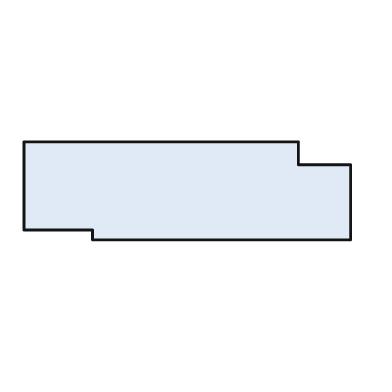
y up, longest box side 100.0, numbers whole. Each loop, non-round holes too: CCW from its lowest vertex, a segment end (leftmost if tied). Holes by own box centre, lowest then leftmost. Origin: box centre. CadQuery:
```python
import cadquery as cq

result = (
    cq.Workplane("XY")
    .moveTo(-29.0, -15.0)
    .lineTo(50.0, -15.0)
    .lineTo(50.0, 8.0)
    .lineTo(34.0, 8.0)
    .lineTo(34.0, 15.0)
    .lineTo(-50.0, 15.0)
    .lineTo(-50.0, -12.0)
    .lineTo(-29.0, -12.0)
    .close()
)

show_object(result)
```